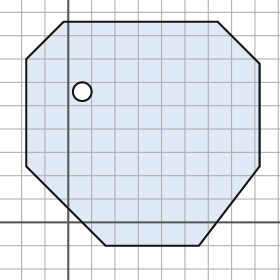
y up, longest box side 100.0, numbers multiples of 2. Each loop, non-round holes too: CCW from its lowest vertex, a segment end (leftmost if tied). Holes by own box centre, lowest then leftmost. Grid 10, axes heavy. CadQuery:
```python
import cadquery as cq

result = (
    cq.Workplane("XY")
    .moveTo(16.0, -10.0)
    .lineTo(56.0, -10.0)
    .lineTo(82.0, 24.0)
    .lineTo(82.0, 68.0)
    .lineTo(64.0, 86.0)
    .lineTo(-2.0, 86.0)
    .lineTo(-18.0, 70.0)
    .lineTo(-18.0, 24.0)
    .close()
    .moveTo(6.0, 56.0)
    .circle(4.0)
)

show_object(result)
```